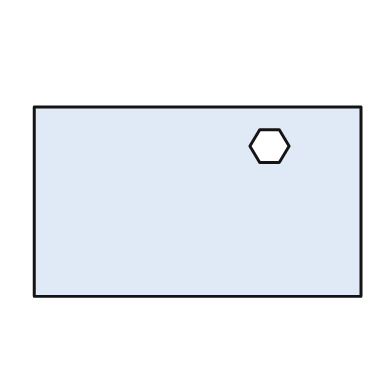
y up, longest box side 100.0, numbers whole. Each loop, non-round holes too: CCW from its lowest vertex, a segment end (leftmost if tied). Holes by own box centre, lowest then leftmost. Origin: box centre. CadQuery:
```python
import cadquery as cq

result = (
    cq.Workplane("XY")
    .moveTo(-50.0, -29.0)
    .lineTo(50.0, -29.0)
    .lineTo(50.0, 29.0)
    .lineTo(-50.0, 29.0)
    .close()
    .moveTo(19.0, 12.0)
    .lineTo(25.0, 12.0)
    .lineTo(28.0, 17.0)
    .lineTo(25.0, 22.0)
    .lineTo(19.0, 22.0)
    .lineTo(16.0, 17.0)
    .close()
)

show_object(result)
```